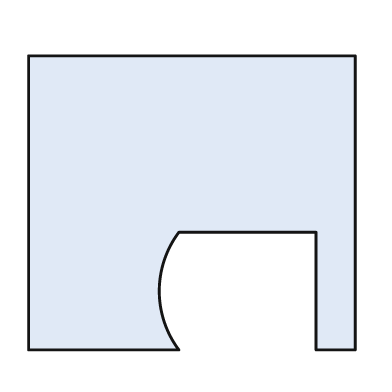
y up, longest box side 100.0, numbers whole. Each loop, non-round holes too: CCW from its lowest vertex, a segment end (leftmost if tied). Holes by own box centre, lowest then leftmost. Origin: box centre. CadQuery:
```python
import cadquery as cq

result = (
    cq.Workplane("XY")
    .moveTo(-50.0, -45.0)
    .lineTo(-4.0, -45.0)
    .threePointArc((-10.0, -27.0), (-4.0, -9.0))
    .lineTo(38.0, -9.0)
    .lineTo(38.0, -45.0)
    .lineTo(50.0, -45.0)
    .lineTo(50.0, 45.0)
    .lineTo(-50.0, 45.0)
    .close()
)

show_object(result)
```